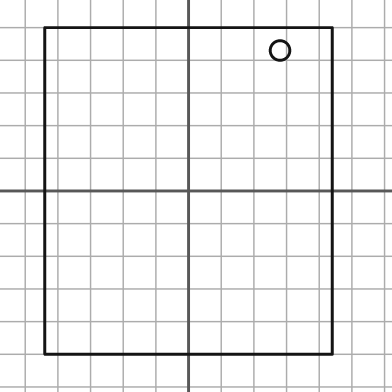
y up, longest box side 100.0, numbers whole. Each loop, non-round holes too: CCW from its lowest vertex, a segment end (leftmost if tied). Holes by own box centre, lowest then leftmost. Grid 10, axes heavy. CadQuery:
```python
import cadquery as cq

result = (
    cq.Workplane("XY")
    .moveTo(-44.0, -50.0)
    .lineTo(44.0, -50.0)
    .lineTo(44.0, 50.0)
    .lineTo(-44.0, 50.0)
    .close()
    .moveTo(28.0, 43.0)
    .circle(3.0)
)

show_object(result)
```